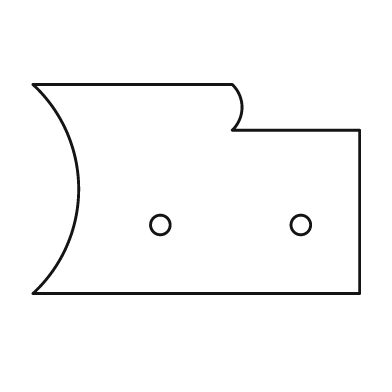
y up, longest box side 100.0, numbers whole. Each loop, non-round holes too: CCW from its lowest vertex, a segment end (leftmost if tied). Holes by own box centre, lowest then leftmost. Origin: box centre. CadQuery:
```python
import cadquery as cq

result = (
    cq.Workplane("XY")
    .moveTo(-50.0, -32.0)
    .lineTo(50.0, -32.0)
    .lineTo(50.0, 18.0)
    .lineTo(11.0, 18.0)
    .threePointArc((14.0, 25.0), (11.0, 32.0))
    .lineTo(-50.0, 32.0)
    .threePointArc((-36.0, 0.0), (-50.0, -32.0))
    .close()
    .moveTo(-11.0, -11.0)
    .circle(3.0)
    .moveTo(32.0, -11.0)
    .circle(3.0)
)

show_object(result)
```